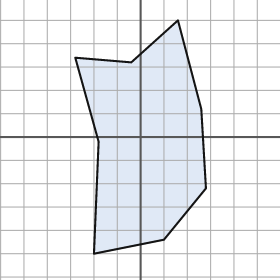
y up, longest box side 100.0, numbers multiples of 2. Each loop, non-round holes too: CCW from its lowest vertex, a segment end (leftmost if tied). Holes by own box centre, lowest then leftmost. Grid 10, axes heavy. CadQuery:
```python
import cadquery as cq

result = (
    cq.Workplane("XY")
    .moveTo(-20.0, -50.0)
    .lineTo(10.0, -44.0)
    .lineTo(28.0, -22.0)
    .lineTo(26.0, 12.0)
    .lineTo(16.0, 50.0)
    .lineTo(-4.0, 32.0)
    .lineTo(-28.0, 34.0)
    .lineTo(-18.0, -2.0)
    .close()
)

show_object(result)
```